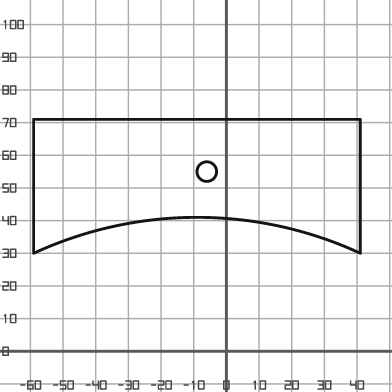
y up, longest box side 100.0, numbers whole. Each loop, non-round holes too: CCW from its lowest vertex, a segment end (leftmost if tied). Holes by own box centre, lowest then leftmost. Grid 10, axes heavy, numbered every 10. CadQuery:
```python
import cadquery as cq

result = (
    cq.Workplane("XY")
    .moveTo(-59.0, 30.0)
    .threePointArc((-9.0, 41.0), (41.0, 30.0))
    .lineTo(41.0, 71.0)
    .lineTo(-59.0, 71.0)
    .close()
    .moveTo(-6.0, 55.0)
    .circle(3.0)
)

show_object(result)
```